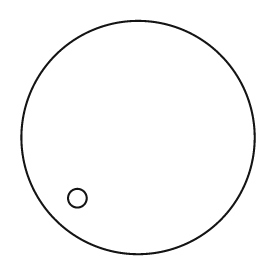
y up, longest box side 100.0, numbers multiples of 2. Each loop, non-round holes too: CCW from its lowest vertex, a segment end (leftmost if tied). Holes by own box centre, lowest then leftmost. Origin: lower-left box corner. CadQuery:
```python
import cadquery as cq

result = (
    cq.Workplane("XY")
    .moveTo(50.0, 50.0)
    .circle(50.0)
    .moveTo(24.0, 24.0)
    .circle(4.0)
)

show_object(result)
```